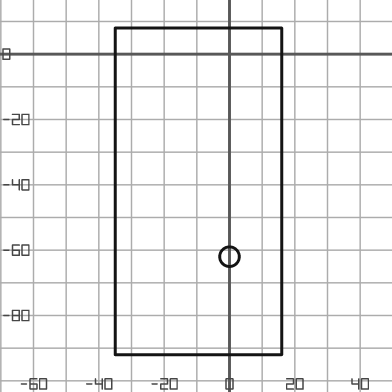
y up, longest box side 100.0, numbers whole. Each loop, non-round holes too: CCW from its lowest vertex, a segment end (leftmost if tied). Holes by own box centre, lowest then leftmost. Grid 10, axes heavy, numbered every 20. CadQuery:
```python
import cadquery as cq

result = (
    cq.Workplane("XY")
    .moveTo(-35.0, -92.0)
    .lineTo(16.0, -92.0)
    .lineTo(16.0, 8.0)
    .lineTo(-35.0, 8.0)
    .close()
    .moveTo(0.0, -62.0)
    .circle(3.0)
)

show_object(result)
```